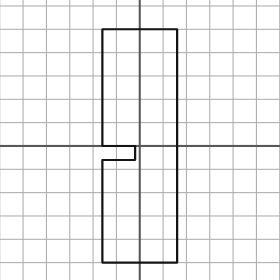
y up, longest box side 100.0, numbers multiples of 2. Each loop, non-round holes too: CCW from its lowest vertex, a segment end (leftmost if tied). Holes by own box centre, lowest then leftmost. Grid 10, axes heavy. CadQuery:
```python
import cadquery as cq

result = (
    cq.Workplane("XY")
    .moveTo(-16.0, -50.0)
    .lineTo(16.0, -50.0)
    .lineTo(16.0, 50.0)
    .lineTo(-16.0, 50.0)
    .lineTo(-16.0, 0.0)
    .lineTo(-2.0, 0.0)
    .lineTo(-2.0, -6.0)
    .lineTo(-16.0, -6.0)
    .close()
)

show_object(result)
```